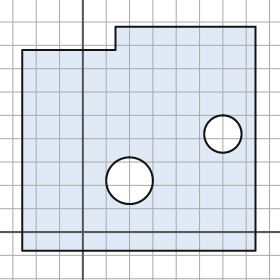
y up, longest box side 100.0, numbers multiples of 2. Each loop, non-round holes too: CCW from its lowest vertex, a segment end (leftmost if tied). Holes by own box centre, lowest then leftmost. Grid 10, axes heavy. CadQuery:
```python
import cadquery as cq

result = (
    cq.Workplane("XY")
    .moveTo(-26.0, -8.0)
    .lineTo(74.0, -8.0)
    .lineTo(74.0, 88.0)
    .lineTo(14.0, 88.0)
    .lineTo(14.0, 78.0)
    .lineTo(-26.0, 78.0)
    .close()
    .moveTo(20.0, 22.0)
    .circle(10.0)
    .moveTo(60.0, 42.0)
    .circle(8.0)
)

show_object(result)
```